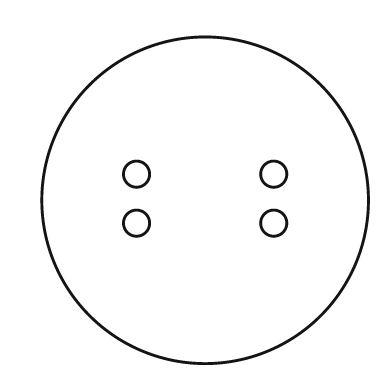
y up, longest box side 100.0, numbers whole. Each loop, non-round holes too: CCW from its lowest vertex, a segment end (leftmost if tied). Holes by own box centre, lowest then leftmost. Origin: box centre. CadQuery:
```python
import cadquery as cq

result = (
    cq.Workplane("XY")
    .moveTo(0.0, 0.0)
    .circle(50.0)
    .moveTo(-21.0, -7.0)
    .circle(4.0)
    .moveTo(21.0, -7.0)
    .circle(4.0)
    .moveTo(-21.0, 8.0)
    .circle(4.0)
    .moveTo(21.0, 8.0)
    .circle(4.0)
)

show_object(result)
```